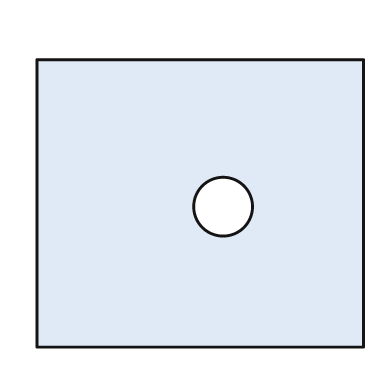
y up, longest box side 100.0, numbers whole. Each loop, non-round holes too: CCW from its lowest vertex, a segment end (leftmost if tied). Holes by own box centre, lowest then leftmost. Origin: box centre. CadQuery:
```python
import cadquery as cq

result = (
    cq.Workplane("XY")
    .moveTo(-50.0, -44.0)
    .lineTo(50.0, -44.0)
    .lineTo(50.0, 44.0)
    .lineTo(-50.0, 44.0)
    .close()
    .moveTo(7.0, -1.0)
    .circle(9.0)
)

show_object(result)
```